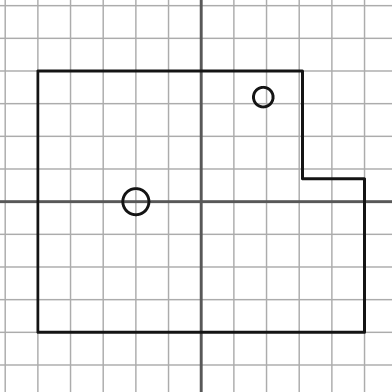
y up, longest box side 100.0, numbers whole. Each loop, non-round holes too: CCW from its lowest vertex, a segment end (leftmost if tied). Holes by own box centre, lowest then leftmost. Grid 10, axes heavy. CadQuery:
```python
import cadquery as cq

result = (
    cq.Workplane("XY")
    .moveTo(-50.0, -40.0)
    .lineTo(50.0, -40.0)
    .lineTo(50.0, 7.0)
    .lineTo(31.0, 7.0)
    .lineTo(31.0, 40.0)
    .lineTo(-50.0, 40.0)
    .close()
    .moveTo(-20.0, 0.0)
    .circle(4.0)
    .moveTo(19.0, 32.0)
    .circle(3.0)
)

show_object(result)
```